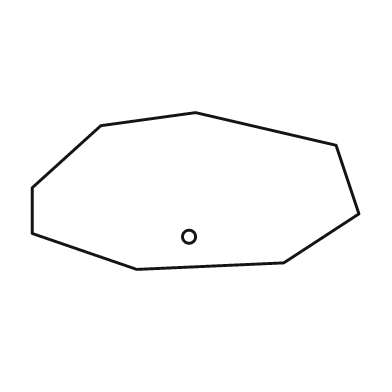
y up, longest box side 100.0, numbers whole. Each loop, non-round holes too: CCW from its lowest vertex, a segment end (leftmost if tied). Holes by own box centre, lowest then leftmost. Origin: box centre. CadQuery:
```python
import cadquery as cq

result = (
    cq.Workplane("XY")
    .moveTo(-18.0, -24.0)
    .lineTo(27.0, -22.0)
    .lineTo(50.0, -7.0)
    .lineTo(43.0, 14.0)
    .lineTo(0.0, 24.0)
    .lineTo(-29.0, 20.0)
    .lineTo(-50.0, 1.0)
    .lineTo(-50.0, -13.0)
    .close()
    .moveTo(-2.0, -14.0)
    .circle(2.0)
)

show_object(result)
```